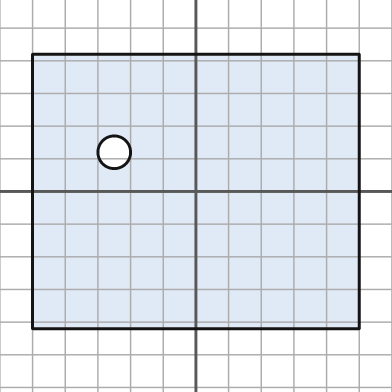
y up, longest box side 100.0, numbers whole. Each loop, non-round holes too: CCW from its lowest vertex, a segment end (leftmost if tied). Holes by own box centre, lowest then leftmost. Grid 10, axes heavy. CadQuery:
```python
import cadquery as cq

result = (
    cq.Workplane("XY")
    .moveTo(-50.0, -42.0)
    .lineTo(50.0, -42.0)
    .lineTo(50.0, 42.0)
    .lineTo(-50.0, 42.0)
    .close()
    .moveTo(-25.0, 12.0)
    .circle(5.0)
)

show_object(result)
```